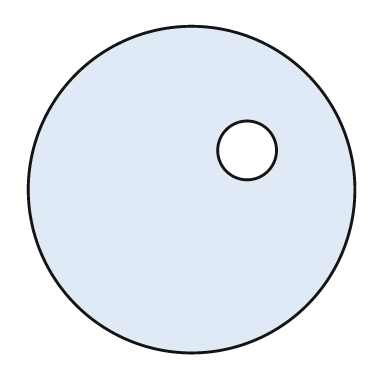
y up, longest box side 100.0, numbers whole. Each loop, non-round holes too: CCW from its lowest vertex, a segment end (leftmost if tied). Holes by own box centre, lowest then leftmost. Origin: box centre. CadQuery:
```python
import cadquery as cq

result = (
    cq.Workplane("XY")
    .moveTo(0.0, 0.0)
    .circle(50.0)
    .moveTo(17.0, 12.0)
    .circle(9.0)
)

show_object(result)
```